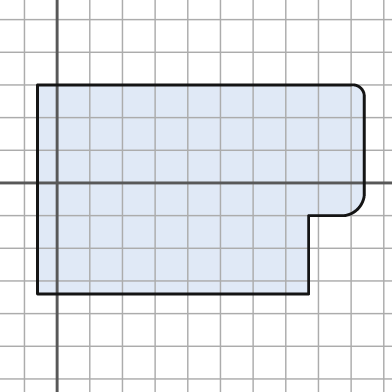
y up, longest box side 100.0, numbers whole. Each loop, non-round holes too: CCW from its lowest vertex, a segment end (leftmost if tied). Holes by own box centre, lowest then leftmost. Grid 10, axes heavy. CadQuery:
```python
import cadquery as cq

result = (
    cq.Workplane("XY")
    .moveTo(-6.0, -34.0)
    .lineTo(77.0, -34.0)
    .lineTo(77.0, -10.0)
    .lineTo(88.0, -10.0)
    .threePointArc((92.0, -8.0), (94.0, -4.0))
    .lineTo(94.0, 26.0)
    .threePointArc((93.0, 29.0), (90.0, 30.0))
    .lineTo(-6.0, 30.0)
    .close()
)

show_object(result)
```